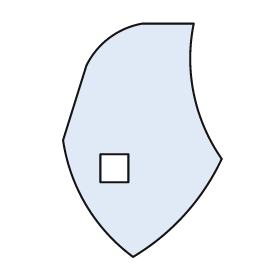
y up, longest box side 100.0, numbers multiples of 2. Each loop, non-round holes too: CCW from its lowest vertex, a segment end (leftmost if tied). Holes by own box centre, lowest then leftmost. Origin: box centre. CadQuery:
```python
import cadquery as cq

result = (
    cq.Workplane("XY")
    .moveTo(-4.0, -50.0)
    .threePointArc((18.0, -32.0), (34.0, -8.0))
    .threePointArc((22.0, 20.0), (22.0, 50.0))
    .lineTo(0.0, 50.0)
    .threePointArc((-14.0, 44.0), (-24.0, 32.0))
    .lineTo(-34.0, 0.0)
    .threePointArc((-24.0, -28.0), (-4.0, -50.0))
    .close()
    .moveTo(-18.0, -18.0)
    .lineTo(-6.0, -18.0)
    .lineTo(-6.0, -6.0)
    .lineTo(-18.0, -6.0)
    .close()
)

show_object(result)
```